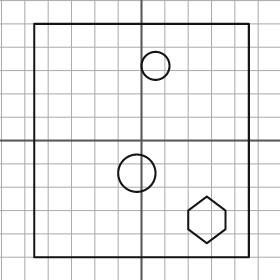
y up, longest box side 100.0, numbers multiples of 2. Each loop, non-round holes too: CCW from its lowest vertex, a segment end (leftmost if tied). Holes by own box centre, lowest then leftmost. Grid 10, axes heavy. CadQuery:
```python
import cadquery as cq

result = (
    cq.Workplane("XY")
    .moveTo(-46.0, -50.0)
    .lineTo(46.0, -50.0)
    .lineTo(46.0, 50.0)
    .lineTo(-46.0, 50.0)
    .close()
    .moveTo(28.0, -44.0)
    .lineTo(36.0, -38.0)
    .lineTo(36.0, -30.0)
    .lineTo(28.0, -24.0)
    .lineTo(20.0, -30.0)
    .lineTo(20.0, -38.0)
    .close()
    .moveTo(-2.0, -14.0)
    .circle(8.0)
    .moveTo(6.0, 32.0)
    .circle(6.0)
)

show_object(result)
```